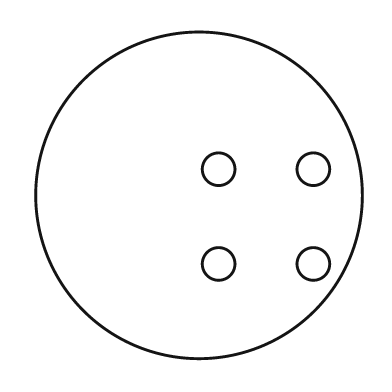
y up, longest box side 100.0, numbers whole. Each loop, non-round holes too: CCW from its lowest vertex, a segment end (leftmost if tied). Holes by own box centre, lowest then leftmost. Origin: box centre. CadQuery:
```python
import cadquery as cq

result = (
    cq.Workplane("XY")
    .moveTo(0.0, 0.0)
    .circle(50.0)
    .moveTo(6.0, -21.0)
    .circle(5.0)
    .moveTo(35.0, -21.0)
    .circle(5.0)
    .moveTo(6.0, 8.0)
    .circle(5.0)
    .moveTo(35.0, 8.0)
    .circle(5.0)
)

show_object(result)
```